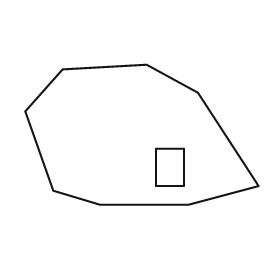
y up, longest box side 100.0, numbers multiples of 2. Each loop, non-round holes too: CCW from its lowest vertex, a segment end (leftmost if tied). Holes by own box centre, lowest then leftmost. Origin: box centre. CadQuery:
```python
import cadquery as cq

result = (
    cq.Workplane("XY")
    .moveTo(-18.0, -30.0)
    .lineTo(20.0, -30.0)
    .lineTo(50.0, -22.0)
    .lineTo(24.0, 18.0)
    .lineTo(2.0, 30.0)
    .lineTo(-34.0, 28.0)
    .lineTo(-50.0, 10.0)
    .lineTo(-38.0, -24.0)
    .close()
    .moveTo(6.0, -22.0)
    .lineTo(18.0, -22.0)
    .lineTo(18.0, -6.0)
    .lineTo(6.0, -6.0)
    .close()
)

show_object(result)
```